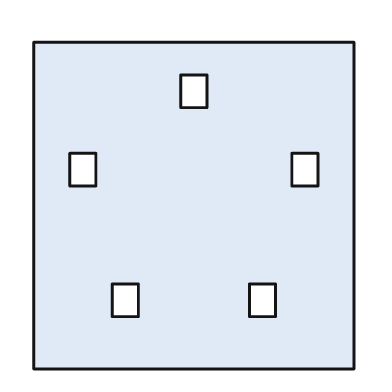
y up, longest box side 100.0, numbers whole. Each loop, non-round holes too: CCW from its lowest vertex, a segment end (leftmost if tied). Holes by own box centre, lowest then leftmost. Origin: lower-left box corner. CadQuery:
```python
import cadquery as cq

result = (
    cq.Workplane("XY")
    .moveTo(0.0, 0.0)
    .lineTo(98.0, 0.0)
    .lineTo(98.0, 100.0)
    .lineTo(0.0, 100.0)
    .close()
    .moveTo(24.0, 16.0)
    .lineTo(32.0, 16.0)
    .lineTo(32.0, 26.0)
    .lineTo(24.0, 26.0)
    .close()
    .moveTo(66.0, 16.0)
    .lineTo(74.0, 16.0)
    .lineTo(74.0, 26.0)
    .lineTo(66.0, 26.0)
    .close()
    .moveTo(11.0, 56.0)
    .lineTo(19.0, 56.0)
    .lineTo(19.0, 66.0)
    .lineTo(11.0, 66.0)
    .close()
    .moveTo(79.0, 56.0)
    .lineTo(87.0, 56.0)
    .lineTo(87.0, 66.0)
    .lineTo(79.0, 66.0)
    .close()
    .moveTo(45.0, 80.0)
    .lineTo(53.0, 80.0)
    .lineTo(53.0, 90.0)
    .lineTo(45.0, 90.0)
    .close()
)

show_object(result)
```